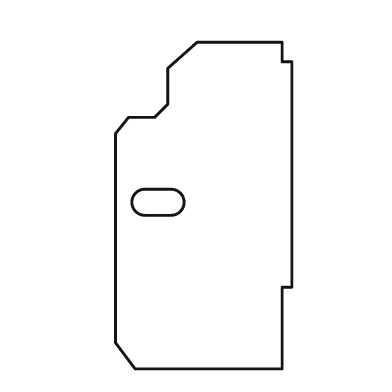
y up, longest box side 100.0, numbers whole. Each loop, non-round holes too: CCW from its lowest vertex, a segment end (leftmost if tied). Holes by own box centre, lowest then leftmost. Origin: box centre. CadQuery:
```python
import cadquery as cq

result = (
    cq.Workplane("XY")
    .moveTo(-21.0, -50.0)
    .lineTo(24.0, -50.0)
    .lineTo(24.0, -25.0)
    .lineTo(27.0, -25.0)
    .lineTo(27.0, 44.0)
    .lineTo(24.0, 44.0)
    .lineTo(24.0, 50.0)
    .lineTo(-2.0, 50.0)
    .lineTo(-11.0, 42.0)
    .lineTo(-11.0, 31.0)
    .lineTo(-15.0, 27.0)
    .lineTo(-23.0, 27.0)
    .lineTo(-27.0, 22.0)
    .lineTo(-27.0, -42.0)
    .close()
    .moveTo(-18.0, -3.0)
    .lineTo(-10.0, -3.0)
    .threePointArc((-6.0, 1.0), (-10.0, 5.0))
    .lineTo(-18.0, 5.0)
    .threePointArc((-22.0, 1.0), (-18.0, -3.0))
    .close()
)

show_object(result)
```